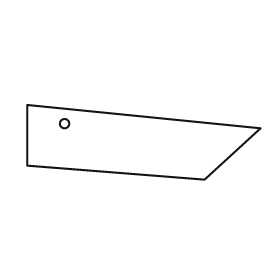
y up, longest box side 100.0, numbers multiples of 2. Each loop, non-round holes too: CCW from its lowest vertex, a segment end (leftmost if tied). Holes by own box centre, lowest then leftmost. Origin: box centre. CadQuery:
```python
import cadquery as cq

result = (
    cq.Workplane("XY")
    .moveTo(26.0, -16.0)
    .lineTo(50.0, 6.0)
    .lineTo(-50.0, 16.0)
    .lineTo(-50.0, -10.0)
    .close()
    .moveTo(-34.0, 8.0)
    .circle(2.0)
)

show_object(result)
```